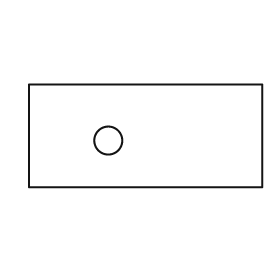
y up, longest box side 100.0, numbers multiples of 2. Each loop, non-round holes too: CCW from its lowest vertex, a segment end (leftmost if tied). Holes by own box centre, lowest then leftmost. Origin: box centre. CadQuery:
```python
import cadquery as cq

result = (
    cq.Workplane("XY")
    .moveTo(-50.0, -22.0)
    .lineTo(50.0, -22.0)
    .lineTo(50.0, 22.0)
    .lineTo(-50.0, 22.0)
    .close()
    .moveTo(-16.0, -2.0)
    .circle(6.0)
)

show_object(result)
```